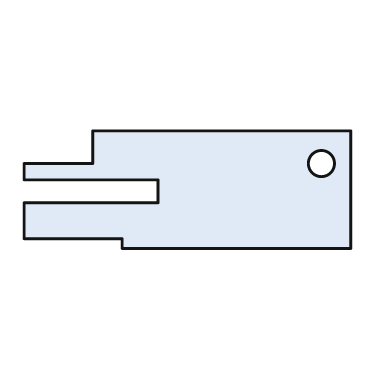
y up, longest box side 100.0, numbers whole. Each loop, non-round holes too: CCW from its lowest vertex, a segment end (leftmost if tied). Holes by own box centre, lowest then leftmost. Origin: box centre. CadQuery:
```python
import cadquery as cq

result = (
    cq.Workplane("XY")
    .moveTo(-20.0, -18.0)
    .lineTo(50.0, -18.0)
    .lineTo(50.0, 18.0)
    .lineTo(-29.0, 18.0)
    .lineTo(-29.0, 8.0)
    .lineTo(-50.0, 8.0)
    .lineTo(-50.0, 3.0)
    .lineTo(-9.0, 3.0)
    .lineTo(-9.0, -4.0)
    .lineTo(-50.0, -4.0)
    .lineTo(-50.0, -15.0)
    .lineTo(-20.0, -15.0)
    .close()
    .moveTo(41.0, 8.0)
    .circle(4.0)
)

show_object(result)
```